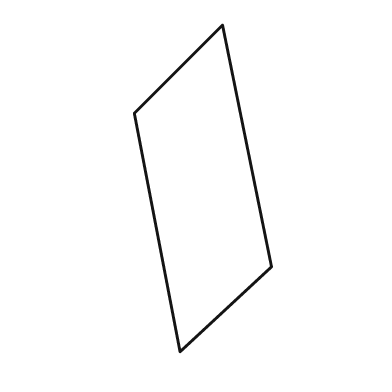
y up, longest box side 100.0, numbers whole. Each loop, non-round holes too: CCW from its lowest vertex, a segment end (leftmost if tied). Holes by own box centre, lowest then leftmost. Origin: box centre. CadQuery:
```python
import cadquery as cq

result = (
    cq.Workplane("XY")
    .moveTo(-7.0, -50.0)
    .lineTo(21.0, -24.0)
    .lineTo(6.0, 50.0)
    .lineTo(-21.0, 23.0)
    .close()
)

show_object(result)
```